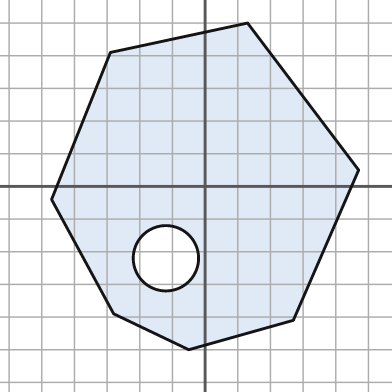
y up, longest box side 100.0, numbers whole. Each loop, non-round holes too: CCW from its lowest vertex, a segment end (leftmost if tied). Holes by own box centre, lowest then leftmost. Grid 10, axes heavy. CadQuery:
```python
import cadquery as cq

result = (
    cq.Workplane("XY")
    .moveTo(-5.0, -50.0)
    .lineTo(27.0, -41.0)
    .lineTo(47.0, 5.0)
    .lineTo(13.0, 50.0)
    .lineTo(-29.0, 41.0)
    .lineTo(-47.0, -4.0)
    .lineTo(-28.0, -39.0)
    .close()
    .moveTo(-12.0, -22.0)
    .circle(10.0)
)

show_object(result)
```